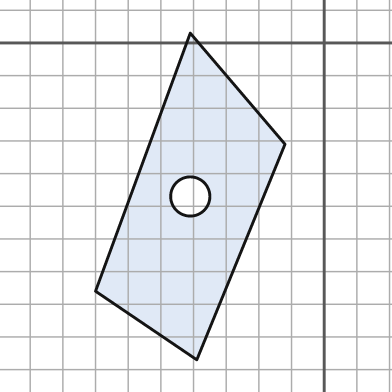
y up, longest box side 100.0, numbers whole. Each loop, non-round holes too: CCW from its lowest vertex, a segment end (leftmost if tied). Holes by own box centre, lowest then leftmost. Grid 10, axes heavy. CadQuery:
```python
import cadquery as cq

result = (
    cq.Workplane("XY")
    .moveTo(-39.0, -97.0)
    .lineTo(-12.0, -31.0)
    .lineTo(-41.0, 3.0)
    .lineTo(-70.0, -76.0)
    .close()
    .moveTo(-41.0, -47.0)
    .circle(6.0)
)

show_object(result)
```